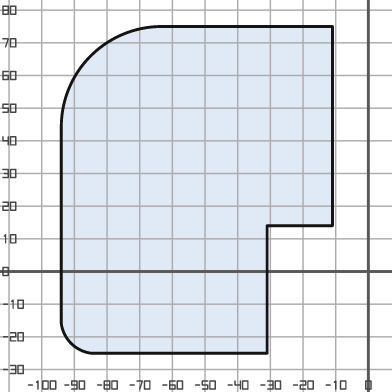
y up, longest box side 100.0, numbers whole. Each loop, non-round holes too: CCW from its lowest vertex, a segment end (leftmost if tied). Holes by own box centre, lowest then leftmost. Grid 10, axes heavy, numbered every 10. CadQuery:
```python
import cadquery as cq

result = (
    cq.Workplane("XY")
    .moveTo(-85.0, -25.0)
    .lineTo(-31.0, -25.0)
    .lineTo(-31.0, 14.0)
    .lineTo(-11.0, 14.0)
    .lineTo(-11.0, 75.0)
    .lineTo(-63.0, 75.0)
    .threePointArc((-85.0, 66.0), (-94.0, 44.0))
    .lineTo(-94.0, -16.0)
    .threePointArc((-91.0, -22.0), (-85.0, -25.0))
    .close()
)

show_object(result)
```